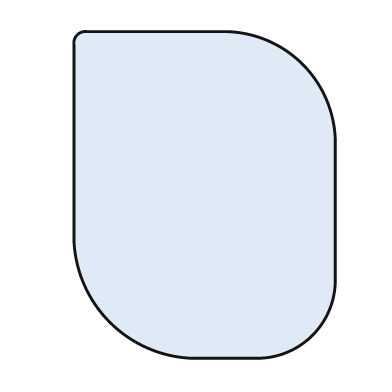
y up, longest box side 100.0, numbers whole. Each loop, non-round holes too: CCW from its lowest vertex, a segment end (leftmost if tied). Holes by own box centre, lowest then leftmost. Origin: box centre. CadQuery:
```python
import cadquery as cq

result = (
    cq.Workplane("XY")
    .moveTo(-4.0, -50.0)
    .lineTo(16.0, -50.0)
    .threePointArc((33.0, -43.0), (40.0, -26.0))
    .lineTo(40.0, 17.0)
    .threePointArc((30.0, 40.0), (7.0, 50.0))
    .lineTo(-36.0, 50.0)
    .threePointArc((-39.0, 49.0), (-40.0, 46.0))
    .lineTo(-40.0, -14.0)
    .threePointArc((-29.0, -39.0), (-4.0, -50.0))
    .close()
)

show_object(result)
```